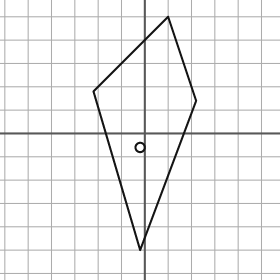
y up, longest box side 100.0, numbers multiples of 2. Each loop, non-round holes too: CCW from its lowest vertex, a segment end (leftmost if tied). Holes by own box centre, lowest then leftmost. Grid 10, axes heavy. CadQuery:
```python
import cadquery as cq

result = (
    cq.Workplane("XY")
    .moveTo(-2.0, -50.0)
    .lineTo(22.0, 14.0)
    .lineTo(10.0, 50.0)
    .lineTo(-22.0, 18.0)
    .close()
    .moveTo(-2.0, -6.0)
    .circle(2.0)
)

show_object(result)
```